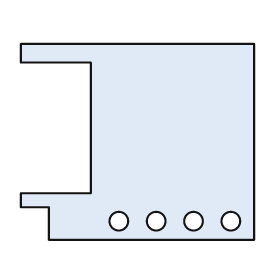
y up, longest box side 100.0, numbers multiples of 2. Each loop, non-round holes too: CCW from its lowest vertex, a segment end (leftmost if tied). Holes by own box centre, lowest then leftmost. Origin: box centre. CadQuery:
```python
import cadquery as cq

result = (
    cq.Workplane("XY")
    .moveTo(-38.0, -42.0)
    .lineTo(50.0, -42.0)
    .lineTo(50.0, 42.0)
    .lineTo(-50.0, 42.0)
    .lineTo(-50.0, 34.0)
    .lineTo(-20.0, 34.0)
    .lineTo(-20.0, -22.0)
    .lineTo(-50.0, -22.0)
    .lineTo(-50.0, -28.0)
    .lineTo(-38.0, -28.0)
    .close()
    .moveTo(-8.0, -34.0)
    .circle(4.0)
    .moveTo(8.0, -34.0)
    .circle(4.0)
    .moveTo(24.0, -34.0)
    .circle(4.0)
    .moveTo(40.0, -34.0)
    .circle(4.0)
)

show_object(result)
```